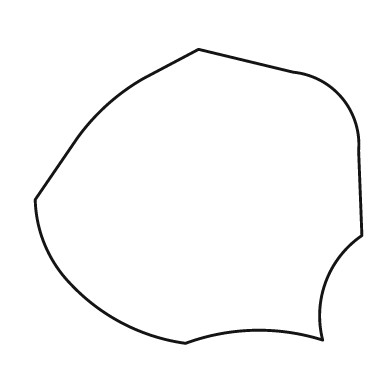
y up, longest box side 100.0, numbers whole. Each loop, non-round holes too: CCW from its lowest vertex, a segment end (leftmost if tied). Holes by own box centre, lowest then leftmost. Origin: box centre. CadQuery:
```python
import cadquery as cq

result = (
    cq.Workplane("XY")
    .moveTo(-4.0, -45.0)
    .threePointArc((17.0, -41.0), (38.0, -44.0))
    .threePointArc((39.0, -26.0), (50.0, -12.0))
    .lineTo(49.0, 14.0)
    .threePointArc((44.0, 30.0), (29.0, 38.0))
    .lineTo(0.0, 45.0)
    .lineTo(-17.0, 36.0)
    .threePointArc((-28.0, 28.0), (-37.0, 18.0))
    .lineTo(-50.0, -1.0)
    .threePointArc((-47.0, -15.0), (-39.0, -27.0))
    .threePointArc((-23.0, -39.0), (-4.0, -45.0))
    .close()
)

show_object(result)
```